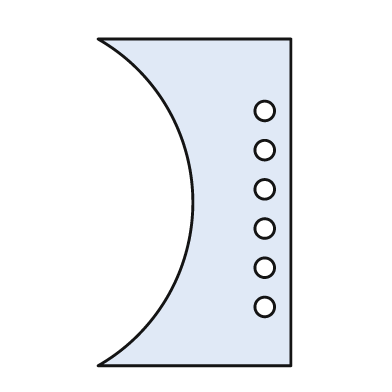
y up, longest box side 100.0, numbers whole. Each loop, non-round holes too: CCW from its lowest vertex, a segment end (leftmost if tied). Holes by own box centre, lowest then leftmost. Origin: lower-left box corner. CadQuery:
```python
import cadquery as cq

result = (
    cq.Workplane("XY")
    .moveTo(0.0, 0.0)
    .lineTo(59.0, 0.0)
    .lineTo(59.0, 100.0)
    .lineTo(0.0, 100.0)
    .threePointArc((29.0, 50.0), (0.0, 0.0))
    .close()
    .moveTo(51.0, 18.0)
    .circle(3.0)
    .moveTo(51.0, 30.0)
    .circle(3.0)
    .moveTo(51.0, 42.0)
    .circle(3.0)
    .moveTo(51.0, 54.0)
    .circle(3.0)
    .moveTo(51.0, 66.0)
    .circle(3.0)
    .moveTo(51.0, 78.0)
    .circle(3.0)
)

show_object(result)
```